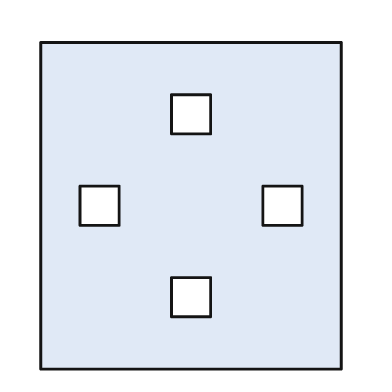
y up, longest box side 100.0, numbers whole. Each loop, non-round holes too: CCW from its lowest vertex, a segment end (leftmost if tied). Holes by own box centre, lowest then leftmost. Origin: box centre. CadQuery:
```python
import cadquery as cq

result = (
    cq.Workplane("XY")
    .moveTo(-46.0, -50.0)
    .lineTo(46.0, -50.0)
    .lineTo(46.0, 50.0)
    .lineTo(-46.0, 50.0)
    .close()
    .moveTo(-6.0, -34.0)
    .lineTo(6.0, -34.0)
    .lineTo(6.0, -22.0)
    .lineTo(-6.0, -22.0)
    .close()
    .moveTo(-34.0, -6.0)
    .lineTo(-22.0, -6.0)
    .lineTo(-22.0, 6.0)
    .lineTo(-34.0, 6.0)
    .close()
    .moveTo(22.0, -6.0)
    .lineTo(34.0, -6.0)
    .lineTo(34.0, 6.0)
    .lineTo(22.0, 6.0)
    .close()
    .moveTo(-6.0, 22.0)
    .lineTo(6.0, 22.0)
    .lineTo(6.0, 34.0)
    .lineTo(-6.0, 34.0)
    .close()
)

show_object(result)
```